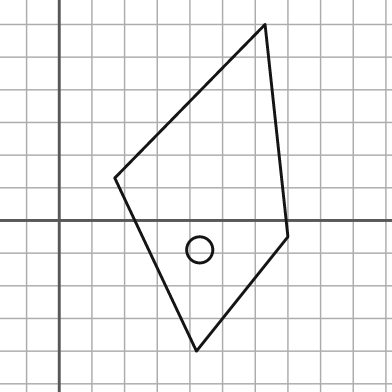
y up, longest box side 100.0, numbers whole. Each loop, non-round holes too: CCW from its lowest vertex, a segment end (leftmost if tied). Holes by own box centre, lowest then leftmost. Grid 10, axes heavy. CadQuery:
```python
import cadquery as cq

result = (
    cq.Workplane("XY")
    .moveTo(42.0, -40.0)
    .lineTo(70.0, -5.0)
    .lineTo(63.0, 60.0)
    .lineTo(17.0, 13.0)
    .close()
    .moveTo(43.0, -9.0)
    .circle(4.0)
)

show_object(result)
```